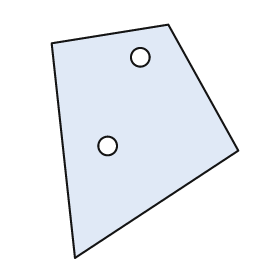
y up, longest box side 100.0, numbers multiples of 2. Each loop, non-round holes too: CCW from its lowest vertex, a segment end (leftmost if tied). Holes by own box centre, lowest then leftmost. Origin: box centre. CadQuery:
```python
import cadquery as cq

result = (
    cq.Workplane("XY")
    .moveTo(-30.0, -50.0)
    .lineTo(40.0, -4.0)
    .lineTo(10.0, 50.0)
    .lineTo(-40.0, 42.0)
    .close()
    .moveTo(-16.0, -2.0)
    .circle(4.0)
    .moveTo(-2.0, 36.0)
    .circle(4.0)
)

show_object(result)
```